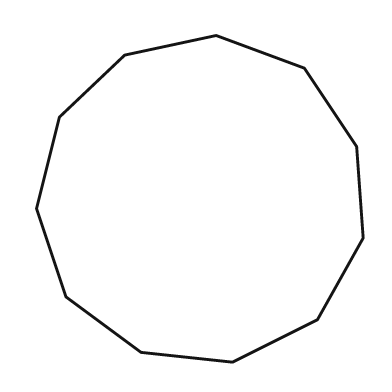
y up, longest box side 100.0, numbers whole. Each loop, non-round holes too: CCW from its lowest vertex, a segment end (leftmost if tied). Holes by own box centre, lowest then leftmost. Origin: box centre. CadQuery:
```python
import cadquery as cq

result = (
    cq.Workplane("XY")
    .moveTo(10.0, -50.0)
    .lineTo(36.0, -37.0)
    .lineTo(50.0, -12.0)
    .lineTo(48.0, 16.0)
    .lineTo(32.0, 40.0)
    .lineTo(5.0, 50.0)
    .lineTo(-23.0, 44.0)
    .lineTo(-43.0, 25.0)
    .lineTo(-50.0, -3.0)
    .lineTo(-41.0, -30.0)
    .lineTo(-18.0, -47.0)
    .close()
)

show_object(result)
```